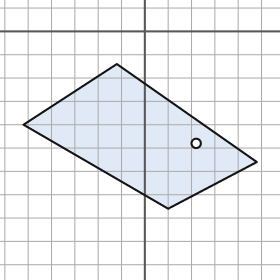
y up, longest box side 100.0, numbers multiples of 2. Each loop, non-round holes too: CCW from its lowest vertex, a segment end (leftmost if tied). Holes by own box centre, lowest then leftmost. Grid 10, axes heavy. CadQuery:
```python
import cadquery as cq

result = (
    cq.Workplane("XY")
    .moveTo(10.0, -76.0)
    .lineTo(48.0, -56.0)
    .lineTo(-12.0, -14.0)
    .lineTo(-52.0, -40.0)
    .close()
    .moveTo(22.0, -48.0)
    .circle(2.0)
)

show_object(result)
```